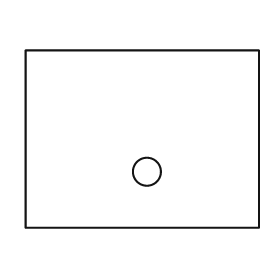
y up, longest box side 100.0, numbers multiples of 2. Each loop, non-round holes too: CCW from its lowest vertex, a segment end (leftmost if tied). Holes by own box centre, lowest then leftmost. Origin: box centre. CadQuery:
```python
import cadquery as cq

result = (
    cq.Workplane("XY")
    .moveTo(-50.0, -38.0)
    .lineTo(50.0, -38.0)
    .lineTo(50.0, 38.0)
    .lineTo(-50.0, 38.0)
    .close()
    .moveTo(2.0, -14.0)
    .circle(6.0)
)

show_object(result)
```